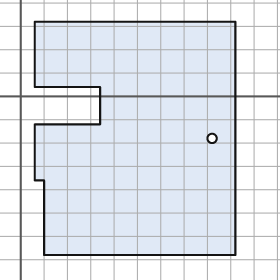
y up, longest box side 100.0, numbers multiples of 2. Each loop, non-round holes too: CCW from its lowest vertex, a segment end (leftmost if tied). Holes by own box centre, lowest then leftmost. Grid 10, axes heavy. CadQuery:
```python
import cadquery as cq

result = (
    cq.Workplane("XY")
    .moveTo(10.0, -68.0)
    .lineTo(92.0, -68.0)
    .lineTo(92.0, 32.0)
    .lineTo(6.0, 32.0)
    .lineTo(6.0, 4.0)
    .lineTo(34.0, 4.0)
    .lineTo(34.0, -12.0)
    .lineTo(6.0, -12.0)
    .lineTo(6.0, -36.0)
    .lineTo(10.0, -36.0)
    .close()
    .moveTo(82.0, -18.0)
    .circle(2.0)
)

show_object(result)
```